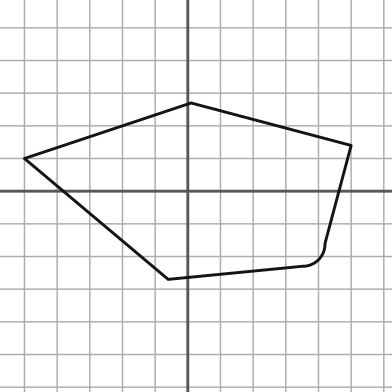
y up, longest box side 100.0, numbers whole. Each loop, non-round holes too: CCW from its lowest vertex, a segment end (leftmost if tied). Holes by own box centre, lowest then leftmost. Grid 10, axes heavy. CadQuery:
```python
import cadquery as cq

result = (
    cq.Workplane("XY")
    .moveTo(-6.0, -27.0)
    .lineTo(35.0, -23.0)
    .threePointArc((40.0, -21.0), (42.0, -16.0))
    .lineTo(50.0, 14.0)
    .lineTo(1.0, 27.0)
    .lineTo(-50.0, 10.0)
    .close()
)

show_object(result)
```